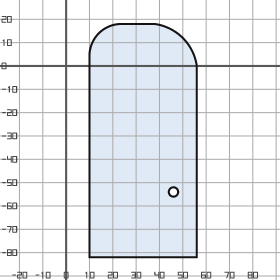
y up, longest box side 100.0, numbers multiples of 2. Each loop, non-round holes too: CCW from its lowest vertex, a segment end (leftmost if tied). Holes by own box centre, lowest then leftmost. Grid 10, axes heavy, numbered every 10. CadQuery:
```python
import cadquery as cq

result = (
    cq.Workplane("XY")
    .moveTo(10.0, -82.0)
    .lineTo(56.0, -82.0)
    .lineTo(56.0, 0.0)
    .threePointArc((50.0, 12.0), (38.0, 18.0))
    .lineTo(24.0, 18.0)
    .threePointArc((14.0, 14.0), (10.0, 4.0))
    .close()
    .moveTo(46.0, -54.0)
    .circle(2.0)
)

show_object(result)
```